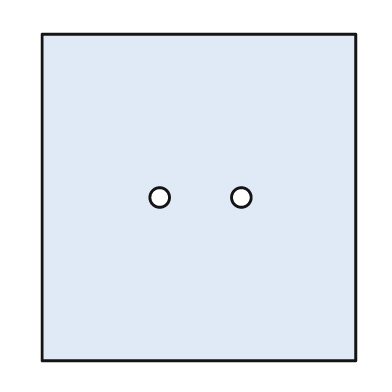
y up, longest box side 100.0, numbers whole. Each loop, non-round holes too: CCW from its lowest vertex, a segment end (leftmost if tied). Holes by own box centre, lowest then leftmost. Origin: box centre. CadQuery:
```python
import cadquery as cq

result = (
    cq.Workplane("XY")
    .moveTo(-48.0, -50.0)
    .lineTo(48.0, -50.0)
    .lineTo(48.0, 50.0)
    .lineTo(-48.0, 50.0)
    .close()
    .moveTo(-12.0, 0.0)
    .circle(3.0)
    .moveTo(13.0, 0.0)
    .circle(3.0)
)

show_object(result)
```